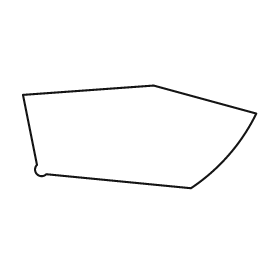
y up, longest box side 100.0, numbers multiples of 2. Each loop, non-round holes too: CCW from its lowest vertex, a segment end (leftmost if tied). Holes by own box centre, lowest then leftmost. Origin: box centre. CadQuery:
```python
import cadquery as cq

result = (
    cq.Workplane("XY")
    .moveTo(22.0, -22.0)
    .threePointArc((38.0, -8.0), (50.0, 10.0))
    .lineTo(6.0, 22.0)
    .lineTo(-50.0, 18.0)
    .lineTo(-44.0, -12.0)
    .threePointArc((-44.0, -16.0), (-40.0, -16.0))
    .close()
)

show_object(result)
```